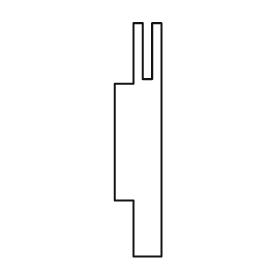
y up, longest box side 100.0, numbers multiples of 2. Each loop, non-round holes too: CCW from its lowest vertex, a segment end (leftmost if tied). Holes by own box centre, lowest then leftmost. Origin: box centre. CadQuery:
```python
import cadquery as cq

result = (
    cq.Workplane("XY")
    .moveTo(-2.0, -50.0)
    .lineTo(10.0, -50.0)
    .lineTo(10.0, 50.0)
    .lineTo(6.0, 50.0)
    .lineTo(6.0, 26.0)
    .lineTo(2.0, 26.0)
    .lineTo(2.0, 50.0)
    .lineTo(-2.0, 50.0)
    .lineTo(-2.0, 24.0)
    .lineTo(-10.0, 24.0)
    .lineTo(-10.0, -26.0)
    .lineTo(-2.0, -26.0)
    .close()
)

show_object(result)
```